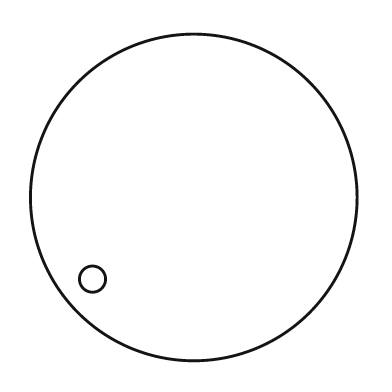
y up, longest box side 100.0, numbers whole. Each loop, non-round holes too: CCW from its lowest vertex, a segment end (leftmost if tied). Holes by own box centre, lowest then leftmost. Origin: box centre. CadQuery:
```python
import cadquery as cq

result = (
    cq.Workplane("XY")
    .moveTo(0.0, 0.0)
    .circle(50.0)
    .moveTo(-31.0, -25.0)
    .circle(4.0)
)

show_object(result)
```